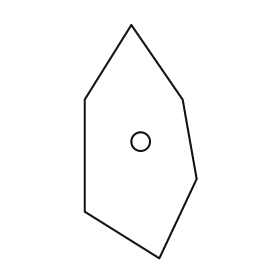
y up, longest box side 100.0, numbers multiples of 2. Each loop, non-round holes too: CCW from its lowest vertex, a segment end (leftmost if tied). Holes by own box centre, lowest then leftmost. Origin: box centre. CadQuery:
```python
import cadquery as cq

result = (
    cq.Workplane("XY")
    .moveTo(8.0, -50.0)
    .lineTo(24.0, -16.0)
    .lineTo(18.0, 18.0)
    .lineTo(-4.0, 50.0)
    .lineTo(-24.0, 18.0)
    .lineTo(-24.0, -30.0)
    .close()
    .moveTo(0.0, 0.0)
    .circle(4.0)
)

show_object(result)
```